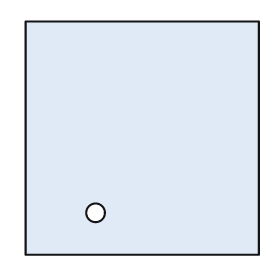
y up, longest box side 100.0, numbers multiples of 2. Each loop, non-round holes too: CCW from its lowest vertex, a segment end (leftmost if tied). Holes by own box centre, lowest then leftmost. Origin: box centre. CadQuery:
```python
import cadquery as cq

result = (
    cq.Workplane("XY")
    .moveTo(-50.0, -50.0)
    .lineTo(50.0, -50.0)
    .lineTo(50.0, 50.0)
    .lineTo(-50.0, 50.0)
    .close()
    .moveTo(-20.0, -32.0)
    .circle(4.0)
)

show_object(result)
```